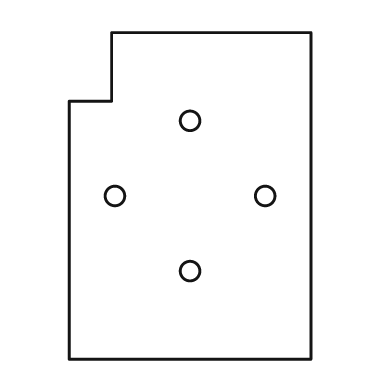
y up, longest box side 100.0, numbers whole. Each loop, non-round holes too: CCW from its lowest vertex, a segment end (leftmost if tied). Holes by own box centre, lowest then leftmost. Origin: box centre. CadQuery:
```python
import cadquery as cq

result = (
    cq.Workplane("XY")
    .moveTo(-37.0, -50.0)
    .lineTo(37.0, -50.0)
    .lineTo(37.0, 50.0)
    .lineTo(-24.0, 50.0)
    .lineTo(-24.0, 29.0)
    .lineTo(-37.0, 29.0)
    .close()
    .moveTo(0.0, -23.0)
    .circle(3.0)
    .moveTo(-23.0, 0.0)
    .circle(3.0)
    .moveTo(23.0, 0.0)
    .circle(3.0)
    .moveTo(0.0, 23.0)
    .circle(3.0)
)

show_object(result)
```